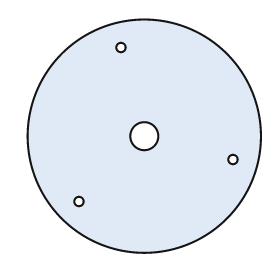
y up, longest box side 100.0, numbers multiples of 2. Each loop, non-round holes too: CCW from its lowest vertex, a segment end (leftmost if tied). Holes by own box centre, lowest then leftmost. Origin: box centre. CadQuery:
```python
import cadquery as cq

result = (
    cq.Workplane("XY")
    .moveTo(0.0, 0.0)
    .circle(50.0)
    .moveTo(-28.0, -28.0)
    .circle(2.0)
    .moveTo(38.0, -10.0)
    .circle(2.0)
    .moveTo(0.0, 0.0)
    .circle(6.0)
    .moveTo(-10.0, 38.0)
    .circle(2.0)
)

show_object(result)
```